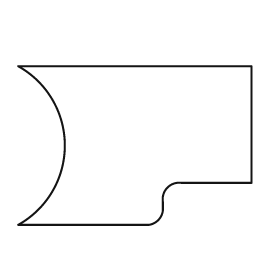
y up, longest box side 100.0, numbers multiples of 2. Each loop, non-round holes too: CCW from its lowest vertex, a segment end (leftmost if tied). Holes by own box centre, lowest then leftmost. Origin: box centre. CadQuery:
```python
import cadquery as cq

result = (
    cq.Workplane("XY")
    .moveTo(-50.0, -34.0)
    .lineTo(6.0, -34.0)
    .threePointArc((10.0, -32.0), (12.0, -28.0))
    .lineTo(12.0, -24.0)
    .threePointArc((14.0, -18.0), (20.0, -16.0))
    .lineTo(50.0, -16.0)
    .lineTo(50.0, 34.0)
    .lineTo(-50.0, 34.0)
    .threePointArc((-30.0, 0.0), (-50.0, -34.0))
    .close()
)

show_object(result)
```